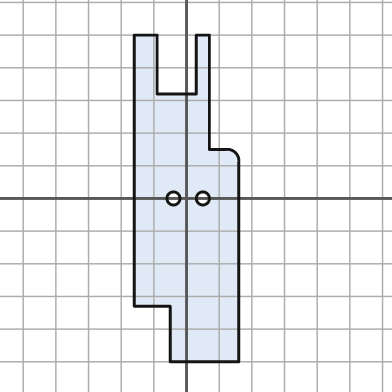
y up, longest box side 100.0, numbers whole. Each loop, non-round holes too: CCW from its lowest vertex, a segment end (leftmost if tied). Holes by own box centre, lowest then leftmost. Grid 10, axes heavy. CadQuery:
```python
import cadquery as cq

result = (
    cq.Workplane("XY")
    .moveTo(-5.0, -50.0)
    .lineTo(16.0, -50.0)
    .lineTo(16.0, 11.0)
    .threePointArc((15.0, 14.0), (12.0, 15.0))
    .lineTo(7.0, 15.0)
    .lineTo(7.0, 50.0)
    .lineTo(3.0, 50.0)
    .lineTo(3.0, 32.0)
    .lineTo(-9.0, 32.0)
    .lineTo(-9.0, 50.0)
    .lineTo(-16.0, 50.0)
    .lineTo(-16.0, -33.0)
    .lineTo(-5.0, -33.0)
    .close()
    .moveTo(-4.0, 0.0)
    .circle(2.0)
    .moveTo(5.0, 0.0)
    .circle(2.0)
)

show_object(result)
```